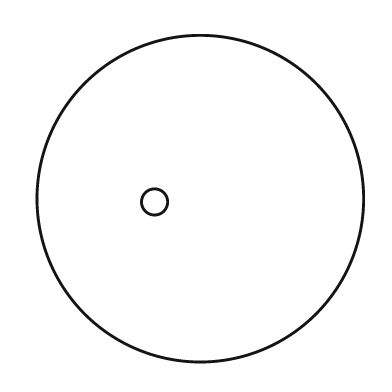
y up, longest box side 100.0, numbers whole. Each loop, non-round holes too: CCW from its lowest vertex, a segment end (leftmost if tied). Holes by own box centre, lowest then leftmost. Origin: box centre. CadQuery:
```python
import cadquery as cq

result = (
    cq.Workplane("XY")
    .moveTo(0.0, 0.0)
    .circle(50.0)
    .moveTo(-14.0, -1.0)
    .circle(4.0)
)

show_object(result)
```